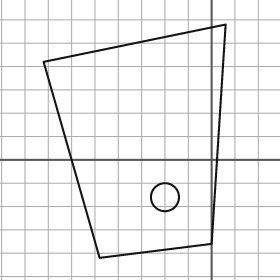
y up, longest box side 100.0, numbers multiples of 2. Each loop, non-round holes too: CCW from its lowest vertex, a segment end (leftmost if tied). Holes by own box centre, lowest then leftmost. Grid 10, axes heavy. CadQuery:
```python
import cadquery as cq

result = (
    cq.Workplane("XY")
    .moveTo(-48.0, -42.0)
    .lineTo(0.0, -36.0)
    .lineTo(6.0, 58.0)
    .lineTo(-72.0, 42.0)
    .close()
    .moveTo(-20.0, -16.0)
    .circle(6.0)
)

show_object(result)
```